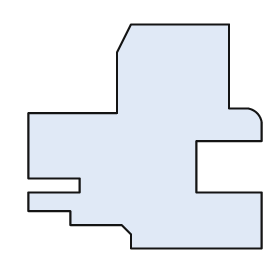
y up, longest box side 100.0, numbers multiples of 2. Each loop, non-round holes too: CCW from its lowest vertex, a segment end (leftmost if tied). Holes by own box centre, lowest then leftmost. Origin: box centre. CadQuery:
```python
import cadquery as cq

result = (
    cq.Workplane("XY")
    .moveTo(-6.0, -48.0)
    .lineTo(50.0, -48.0)
    .lineTo(50.0, -24.0)
    .lineTo(22.0, -24.0)
    .lineTo(22.0, -2.0)
    .lineTo(50.0, -2.0)
    .lineTo(50.0, 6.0)
    .threePointArc((48.0, 10.0), (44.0, 12.0))
    .lineTo(36.0, 12.0)
    .lineTo(36.0, 48.0)
    .lineTo(-6.0, 48.0)
    .lineTo(-12.0, 36.0)
    .lineTo(-12.0, 10.0)
    .lineTo(-50.0, 10.0)
    .lineTo(-50.0, -18.0)
    .lineTo(-28.0, -18.0)
    .lineTo(-28.0, -24.0)
    .lineTo(-50.0, -24.0)
    .lineTo(-50.0, -32.0)
    .lineTo(-32.0, -32.0)
    .lineTo(-32.0, -38.0)
    .lineTo(-10.0, -38.0)
    .lineTo(-6.0, -42.0)
    .close()
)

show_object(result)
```